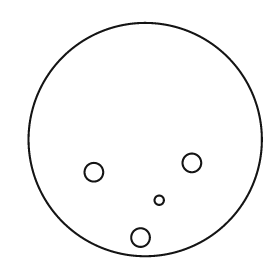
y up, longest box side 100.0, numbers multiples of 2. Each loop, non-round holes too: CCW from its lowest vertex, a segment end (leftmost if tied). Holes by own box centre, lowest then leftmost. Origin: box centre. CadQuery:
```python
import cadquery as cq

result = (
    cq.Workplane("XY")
    .moveTo(0.0, 0.0)
    .circle(50.0)
    .moveTo(-2.0, -42.0)
    .circle(4.0)
    .moveTo(6.0, -26.0)
    .circle(2.0)
    .moveTo(-22.0, -14.0)
    .circle(4.0)
    .moveTo(20.0, -10.0)
    .circle(4.0)
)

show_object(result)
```